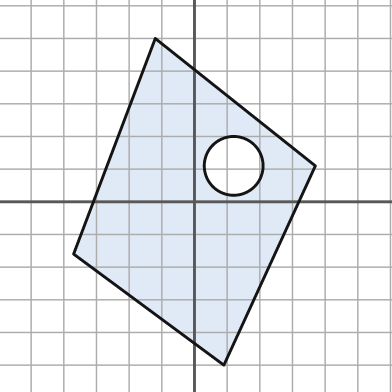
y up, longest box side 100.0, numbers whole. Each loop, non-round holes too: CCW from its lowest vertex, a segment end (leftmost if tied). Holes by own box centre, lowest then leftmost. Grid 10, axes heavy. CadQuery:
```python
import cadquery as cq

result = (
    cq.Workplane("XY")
    .moveTo(9.0, -50.0)
    .lineTo(37.0, 11.0)
    .lineTo(-12.0, 50.0)
    .lineTo(-37.0, -16.0)
    .close()
    .moveTo(12.0, 11.0)
    .circle(9.0)
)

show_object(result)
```